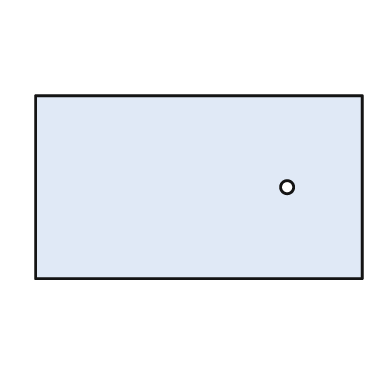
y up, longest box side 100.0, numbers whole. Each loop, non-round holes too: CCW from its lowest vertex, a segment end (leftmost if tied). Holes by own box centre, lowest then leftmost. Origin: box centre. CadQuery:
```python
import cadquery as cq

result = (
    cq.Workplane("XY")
    .moveTo(-50.0, -28.0)
    .lineTo(50.0, -28.0)
    .lineTo(50.0, 28.0)
    .lineTo(-50.0, 28.0)
    .close()
    .moveTo(27.0, 0.0)
    .circle(2.0)
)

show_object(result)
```